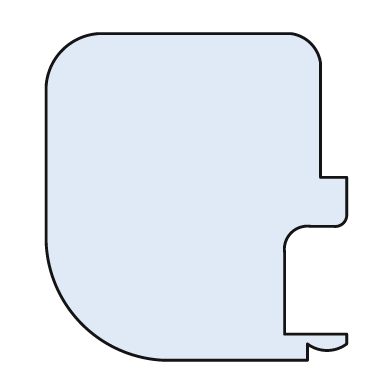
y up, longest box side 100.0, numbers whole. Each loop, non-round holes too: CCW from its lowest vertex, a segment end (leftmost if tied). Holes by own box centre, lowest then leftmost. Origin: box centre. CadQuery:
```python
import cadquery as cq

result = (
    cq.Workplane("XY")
    .moveTo(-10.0, -50.0)
    .lineTo(34.0, -50.0)
    .lineTo(34.0, -45.0)
    .threePointArc((40.0, -47.0), (46.0, -45.0))
    .lineTo(46.0, -42.0)
    .lineTo(27.0, -42.0)
    .lineTo(27.0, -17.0)
    .threePointArc((29.0, -11.0), (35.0, -9.0))
    .lineTo(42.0, -9.0)
    .threePointArc((45.0, -8.0), (46.0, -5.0))
    .lineTo(46.0, 6.0)
    .lineTo(38.0, 6.0)
    .lineTo(38.0, 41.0)
    .threePointArc((35.0, 47.0), (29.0, 50.0))
    .lineTo(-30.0, 50.0)
    .threePointArc((-41.0, 45.0), (-46.0, 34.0))
    .lineTo(-46.0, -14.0)
    .threePointArc((-35.0, -39.0), (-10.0, -50.0))
    .close()
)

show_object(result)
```